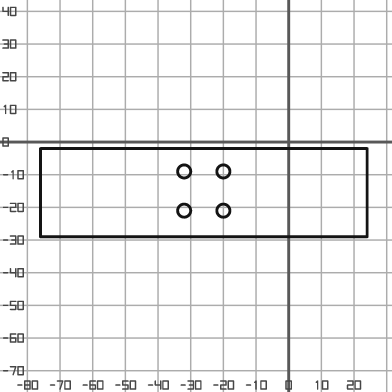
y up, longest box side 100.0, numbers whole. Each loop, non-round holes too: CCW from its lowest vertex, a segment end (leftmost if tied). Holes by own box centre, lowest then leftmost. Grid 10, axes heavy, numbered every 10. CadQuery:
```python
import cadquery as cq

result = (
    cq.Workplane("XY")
    .moveTo(-76.0, -29.0)
    .lineTo(24.0, -29.0)
    .lineTo(24.0, -2.0)
    .lineTo(-76.0, -2.0)
    .close()
    .moveTo(-32.0, -21.0)
    .circle(2.0)
    .moveTo(-20.0, -21.0)
    .circle(2.0)
    .moveTo(-32.0, -9.0)
    .circle(2.0)
    .moveTo(-20.0, -9.0)
    .circle(2.0)
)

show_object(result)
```